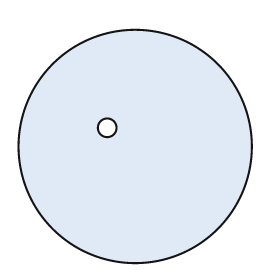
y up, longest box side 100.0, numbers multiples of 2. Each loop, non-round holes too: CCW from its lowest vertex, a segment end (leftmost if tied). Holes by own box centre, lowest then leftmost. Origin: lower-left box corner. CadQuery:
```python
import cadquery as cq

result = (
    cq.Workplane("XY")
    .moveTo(50.0, 50.0)
    .circle(50.0)
    .moveTo(38.0, 58.0)
    .circle(4.0)
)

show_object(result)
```